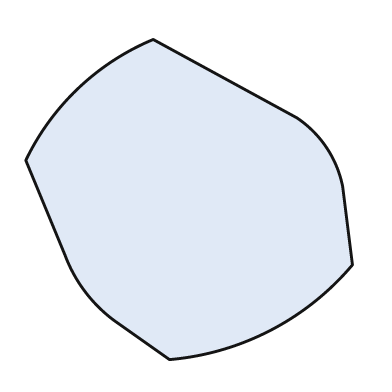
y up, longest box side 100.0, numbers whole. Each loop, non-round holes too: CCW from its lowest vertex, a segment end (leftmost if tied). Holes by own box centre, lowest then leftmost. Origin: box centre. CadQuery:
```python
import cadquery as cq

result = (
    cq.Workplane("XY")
    .moveTo(-6.0, -49.0)
    .threePointArc((25.0, -40.0), (50.0, -20.0))
    .lineTo(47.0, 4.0)
    .threePointArc((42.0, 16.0), (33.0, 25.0))
    .lineTo(-11.0, 49.0)
    .threePointArc((-34.0, 34.0), (-50.0, 12.0))
    .lineTo(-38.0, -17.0)
    .threePointArc((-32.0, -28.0), (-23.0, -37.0))
    .close()
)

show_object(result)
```